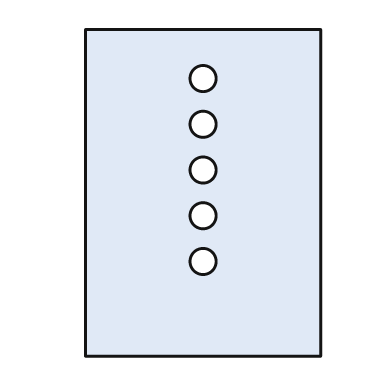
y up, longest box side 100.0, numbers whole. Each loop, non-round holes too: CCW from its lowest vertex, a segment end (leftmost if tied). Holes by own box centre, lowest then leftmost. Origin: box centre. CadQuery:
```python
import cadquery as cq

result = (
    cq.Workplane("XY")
    .moveTo(-36.0, -50.0)
    .lineTo(36.0, -50.0)
    .lineTo(36.0, 50.0)
    .lineTo(-36.0, 50.0)
    .close()
    .moveTo(0.0, -21.0)
    .circle(4.0)
    .moveTo(0.0, -7.0)
    .circle(4.0)
    .moveTo(0.0, 7.0)
    .circle(4.0)
    .moveTo(0.0, 21.0)
    .circle(4.0)
    .moveTo(0.0, 35.0)
    .circle(4.0)
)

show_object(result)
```